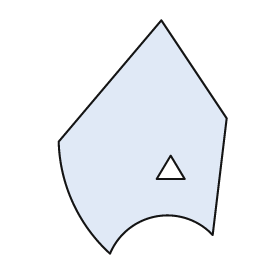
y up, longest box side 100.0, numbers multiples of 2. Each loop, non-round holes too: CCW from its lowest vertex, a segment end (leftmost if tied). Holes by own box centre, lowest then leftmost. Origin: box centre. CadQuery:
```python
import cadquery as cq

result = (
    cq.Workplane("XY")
    .moveTo(-14.0, -50.0)
    .threePointArc((6.0, -34.0), (30.0, -42.0))
    .lineTo(36.0, 8.0)
    .lineTo(8.0, 50.0)
    .lineTo(-36.0, -2.0)
    .threePointArc((-30.0, -28.0), (-14.0, -50.0))
    .close()
    .moveTo(6.0, -18.0)
    .lineTo(18.0, -18.0)
    .lineTo(12.0, -8.0)
    .close()
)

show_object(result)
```